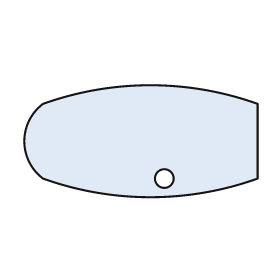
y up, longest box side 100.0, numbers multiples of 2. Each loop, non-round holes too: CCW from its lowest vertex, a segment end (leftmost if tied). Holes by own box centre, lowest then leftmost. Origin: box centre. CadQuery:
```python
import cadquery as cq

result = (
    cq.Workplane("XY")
    .moveTo(-42.0, -16.0)
    .threePointArc((4.0, -24.0), (50.0, -16.0))
    .lineTo(50.0, 16.0)
    .threePointArc((4.0, 24.0), (-42.0, 16.0))
    .threePointArc((-50.0, 0.0), (-42.0, -16.0))
    .close()
    .moveTo(10.0, -16.0)
    .circle(4.0)
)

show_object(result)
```